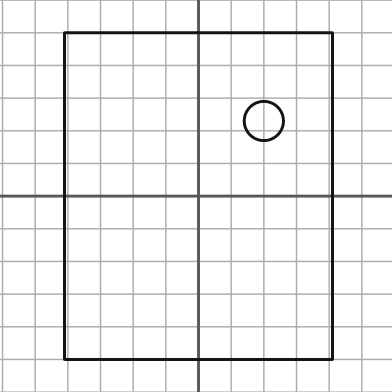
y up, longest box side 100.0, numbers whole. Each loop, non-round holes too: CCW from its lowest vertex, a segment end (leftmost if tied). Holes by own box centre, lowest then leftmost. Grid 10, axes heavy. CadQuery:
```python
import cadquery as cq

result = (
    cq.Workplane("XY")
    .moveTo(-41.0, -50.0)
    .lineTo(41.0, -50.0)
    .lineTo(41.0, 50.0)
    .lineTo(-41.0, 50.0)
    .close()
    .moveTo(20.0, 23.0)
    .circle(6.0)
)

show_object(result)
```